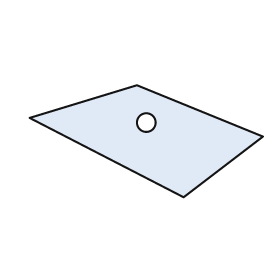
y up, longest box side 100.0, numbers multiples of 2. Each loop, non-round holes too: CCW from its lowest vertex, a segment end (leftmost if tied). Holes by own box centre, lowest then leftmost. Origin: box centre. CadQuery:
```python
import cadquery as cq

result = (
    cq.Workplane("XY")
    .moveTo(16.0, -24.0)
    .lineTo(50.0, 2.0)
    .lineTo(-4.0, 24.0)
    .lineTo(-50.0, 10.0)
    .close()
    .moveTo(0.0, 8.0)
    .circle(4.0)
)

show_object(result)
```